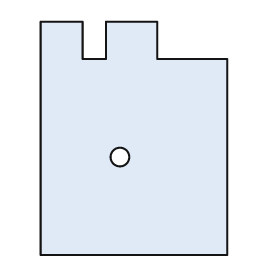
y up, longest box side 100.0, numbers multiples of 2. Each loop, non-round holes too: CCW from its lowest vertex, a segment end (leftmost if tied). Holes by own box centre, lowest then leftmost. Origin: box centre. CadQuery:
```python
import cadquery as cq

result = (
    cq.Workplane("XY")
    .moveTo(-40.0, -50.0)
    .lineTo(40.0, -50.0)
    .lineTo(40.0, 34.0)
    .lineTo(10.0, 34.0)
    .lineTo(10.0, 50.0)
    .lineTo(-12.0, 50.0)
    .lineTo(-12.0, 34.0)
    .lineTo(-22.0, 34.0)
    .lineTo(-22.0, 50.0)
    .lineTo(-40.0, 50.0)
    .close()
    .moveTo(-6.0, -8.0)
    .circle(4.0)
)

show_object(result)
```